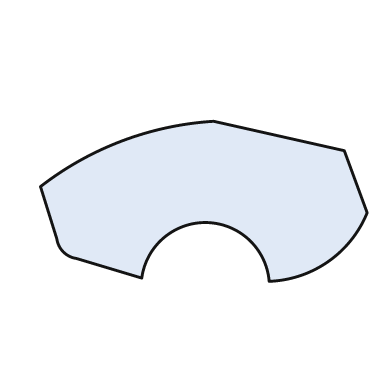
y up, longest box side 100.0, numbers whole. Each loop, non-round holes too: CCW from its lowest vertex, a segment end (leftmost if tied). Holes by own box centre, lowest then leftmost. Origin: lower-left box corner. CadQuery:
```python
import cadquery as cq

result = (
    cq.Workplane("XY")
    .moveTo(70.0, 0.0)
    .threePointArc((88.0, 6.0), (100.0, 21.0))
    .lineTo(93.0, 40.0)
    .lineTo(53.0, 49.0)
    .threePointArc((25.0, 43.0), (0.0, 29.0))
    .lineTo(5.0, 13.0)
    .threePointArc((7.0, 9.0), (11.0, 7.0))
    .lineTo(31.0, 1.0)
    .threePointArc((51.0, 18.0), (70.0, 0.0))
    .close()
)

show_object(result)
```